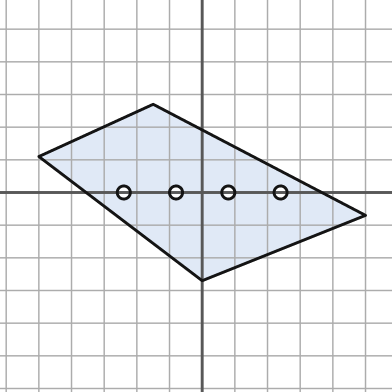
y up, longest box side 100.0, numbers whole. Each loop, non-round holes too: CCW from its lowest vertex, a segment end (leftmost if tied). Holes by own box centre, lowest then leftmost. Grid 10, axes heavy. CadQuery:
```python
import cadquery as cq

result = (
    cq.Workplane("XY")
    .moveTo(0.0, -27.0)
    .lineTo(50.0, -7.0)
    .lineTo(-15.0, 27.0)
    .lineTo(-50.0, 11.0)
    .close()
    .moveTo(-24.0, 0.0)
    .circle(2.0)
    .moveTo(-8.0, 0.0)
    .circle(2.0)
    .moveTo(8.0, 0.0)
    .circle(2.0)
    .moveTo(24.0, 0.0)
    .circle(2.0)
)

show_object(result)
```